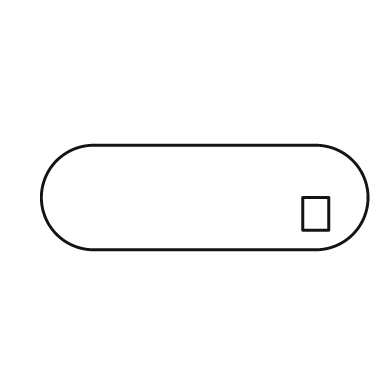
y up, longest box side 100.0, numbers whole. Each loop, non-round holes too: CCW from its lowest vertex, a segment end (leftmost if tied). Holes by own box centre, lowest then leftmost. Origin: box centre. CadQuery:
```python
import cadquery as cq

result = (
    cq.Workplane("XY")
    .moveTo(-34.0, -16.0)
    .lineTo(34.0, -16.0)
    .threePointArc((50.0, 0.0), (34.0, 16.0))
    .lineTo(-34.0, 16.0)
    .threePointArc((-50.0, 0.0), (-34.0, -16.0))
    .close()
    .moveTo(30.0, -10.0)
    .lineTo(38.0, -10.0)
    .lineTo(38.0, 0.0)
    .lineTo(30.0, 0.0)
    .close()
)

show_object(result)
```